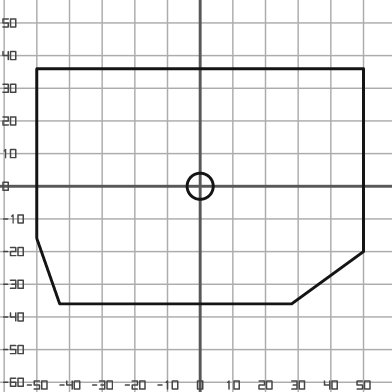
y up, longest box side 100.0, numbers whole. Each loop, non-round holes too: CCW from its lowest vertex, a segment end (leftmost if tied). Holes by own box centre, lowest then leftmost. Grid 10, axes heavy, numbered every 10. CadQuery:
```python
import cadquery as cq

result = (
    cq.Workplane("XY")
    .moveTo(-43.0, -36.0)
    .lineTo(28.0, -36.0)
    .lineTo(50.0, -20.0)
    .lineTo(50.0, 36.0)
    .lineTo(-50.0, 36.0)
    .lineTo(-50.0, -16.0)
    .close()
    .moveTo(0.0, 0.0)
    .circle(4.0)
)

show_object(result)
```